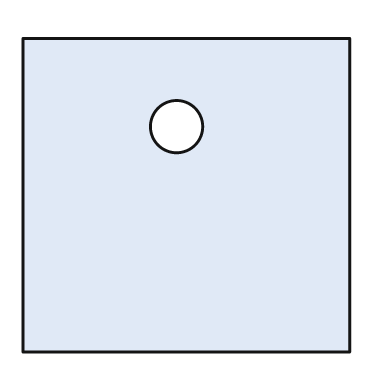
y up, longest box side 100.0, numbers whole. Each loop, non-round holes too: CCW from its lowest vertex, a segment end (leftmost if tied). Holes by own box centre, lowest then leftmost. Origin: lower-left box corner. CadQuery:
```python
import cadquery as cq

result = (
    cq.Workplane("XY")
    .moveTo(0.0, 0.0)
    .lineTo(100.0, 0.0)
    .lineTo(100.0, 96.0)
    .lineTo(0.0, 96.0)
    .close()
    .moveTo(47.0, 69.0)
    .circle(8.0)
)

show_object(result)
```